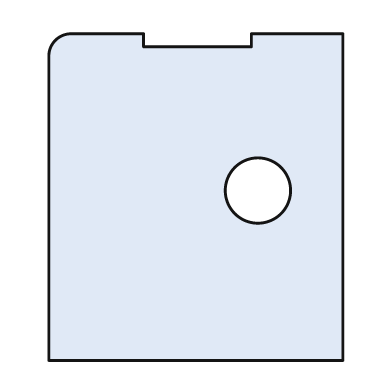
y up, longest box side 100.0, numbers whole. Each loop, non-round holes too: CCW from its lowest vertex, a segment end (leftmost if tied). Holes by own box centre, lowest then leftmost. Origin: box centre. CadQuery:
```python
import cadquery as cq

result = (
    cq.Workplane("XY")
    .moveTo(-45.0, -50.0)
    .lineTo(45.0, -50.0)
    .lineTo(45.0, 50.0)
    .lineTo(17.0, 50.0)
    .lineTo(17.0, 46.0)
    .lineTo(-16.0, 46.0)
    .lineTo(-16.0, 50.0)
    .lineTo(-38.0, 50.0)
    .threePointArc((-43.0, 48.0), (-45.0, 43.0))
    .close()
    .moveTo(19.0, 2.0)
    .circle(10.0)
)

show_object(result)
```